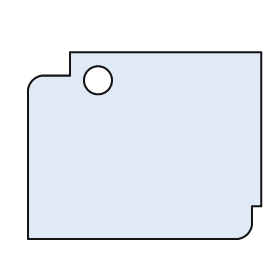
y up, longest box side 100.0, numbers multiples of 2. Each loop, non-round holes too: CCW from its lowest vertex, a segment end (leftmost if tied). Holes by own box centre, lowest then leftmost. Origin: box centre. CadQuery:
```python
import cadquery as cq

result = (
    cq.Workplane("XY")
    .moveTo(-50.0, -40.0)
    .lineTo(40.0, -40.0)
    .threePointArc((44.0, -38.0), (46.0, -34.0))
    .lineTo(46.0, -26.0)
    .lineTo(50.0, -26.0)
    .lineTo(50.0, 40.0)
    .lineTo(-32.0, 40.0)
    .lineTo(-32.0, 30.0)
    .lineTo(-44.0, 30.0)
    .threePointArc((-48.0, 28.0), (-50.0, 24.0))
    .close()
    .moveTo(-20.0, 28.0)
    .circle(6.0)
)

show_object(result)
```